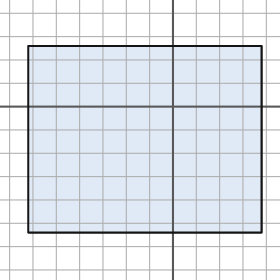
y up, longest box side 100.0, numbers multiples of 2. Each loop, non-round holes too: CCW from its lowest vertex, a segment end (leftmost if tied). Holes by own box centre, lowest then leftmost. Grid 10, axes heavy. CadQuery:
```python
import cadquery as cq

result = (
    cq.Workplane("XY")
    .moveTo(-62.0, -54.0)
    .lineTo(38.0, -54.0)
    .lineTo(38.0, 26.0)
    .lineTo(-62.0, 26.0)
    .close()
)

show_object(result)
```